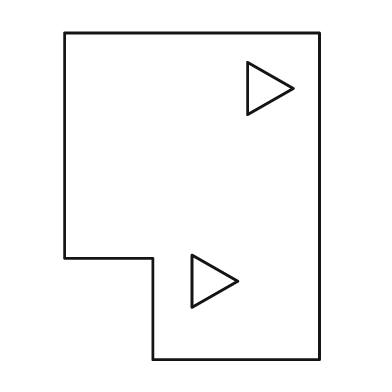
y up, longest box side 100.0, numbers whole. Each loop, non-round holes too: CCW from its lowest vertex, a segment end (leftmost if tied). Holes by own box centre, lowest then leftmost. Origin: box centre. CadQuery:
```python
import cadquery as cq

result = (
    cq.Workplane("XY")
    .moveTo(-12.0, -50.0)
    .lineTo(39.0, -50.0)
    .lineTo(39.0, 50.0)
    .lineTo(-39.0, 50.0)
    .lineTo(-39.0, -19.0)
    .lineTo(-12.0, -19.0)
    .close()
    .moveTo(0.0, -34.0)
    .lineTo(14.0, -26.0)
    .lineTo(0.0, -18.0)
    .close()
    .moveTo(17.0, 25.0)
    .lineTo(31.0, 33.0)
    .lineTo(17.0, 41.0)
    .close()
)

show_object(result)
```